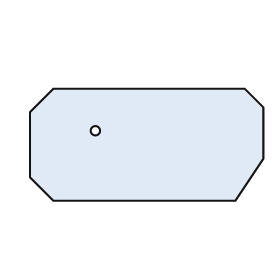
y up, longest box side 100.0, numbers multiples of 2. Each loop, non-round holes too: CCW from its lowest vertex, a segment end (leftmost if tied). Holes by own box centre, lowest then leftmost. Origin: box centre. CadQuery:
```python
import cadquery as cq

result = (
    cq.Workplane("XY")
    .moveTo(-40.0, -24.0)
    .lineTo(38.0, -24.0)
    .lineTo(50.0, -6.0)
    .lineTo(50.0, 16.0)
    .lineTo(42.0, 24.0)
    .lineTo(-40.0, 24.0)
    .lineTo(-50.0, 14.0)
    .lineTo(-50.0, -14.0)
    .close()
    .moveTo(-22.0, 6.0)
    .circle(2.0)
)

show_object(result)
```